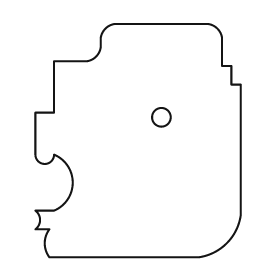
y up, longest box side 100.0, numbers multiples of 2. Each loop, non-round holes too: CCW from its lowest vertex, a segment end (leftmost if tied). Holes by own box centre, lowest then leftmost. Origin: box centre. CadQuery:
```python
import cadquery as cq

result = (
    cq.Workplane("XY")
    .moveTo(-38.0, -50.0)
    .lineTo(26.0, -50.0)
    .threePointArc((38.0, -44.0), (44.0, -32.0))
    .lineTo(44.0, 24.0)
    .lineTo(40.0, 24.0)
    .lineTo(40.0, 32.0)
    .lineTo(36.0, 32.0)
    .lineTo(36.0, 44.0)
    .threePointArc((34.0, 48.0), (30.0, 50.0))
    .lineTo(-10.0, 50.0)
    .threePointArc((-14.0, 48.0), (-16.0, 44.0))
    .lineTo(-16.0, 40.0)
    .threePointArc((-18.0, 36.0), (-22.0, 34.0))
    .lineTo(-36.0, 34.0)
    .lineTo(-36.0, 12.0)
    .lineTo(-44.0, 12.0)
    .lineTo(-44.0, -6.0)
    .threePointArc((-40.0, -10.0), (-36.0, -6.0))
    .threePointArc((-28.0, -18.0), (-36.0, -30.0))
    .lineTo(-44.0, -30.0)
    .threePointArc((-42.0, -34.0), (-44.0, -38.0))
    .lineTo(-38.0, -38.0)
    .threePointArc((-40.0, -44.0), (-38.0, -50.0))
    .close()
    .moveTo(10.0, 10.0)
    .circle(4.0)
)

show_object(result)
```